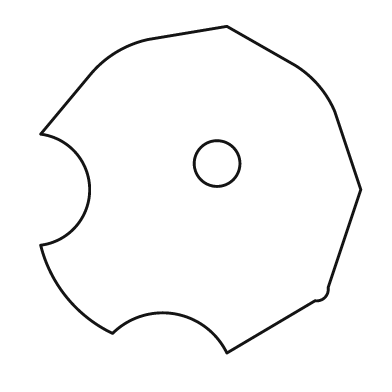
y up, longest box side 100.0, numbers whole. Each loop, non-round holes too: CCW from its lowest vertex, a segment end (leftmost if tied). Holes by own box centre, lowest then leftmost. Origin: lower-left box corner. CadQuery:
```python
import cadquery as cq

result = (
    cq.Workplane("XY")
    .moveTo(57.0, 0.0)
    .lineTo(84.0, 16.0)
    .threePointArc((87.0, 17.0), (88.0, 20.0))
    .lineTo(98.0, 50.0)
    .lineTo(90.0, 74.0)
    .threePointArc((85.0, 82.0), (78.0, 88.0))
    .lineTo(57.0, 100.0)
    .lineTo(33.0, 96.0)
    .threePointArc((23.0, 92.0), (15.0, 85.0))
    .lineTo(0.0, 67.0)
    .threePointArc((15.0, 50.0), (0.0, 33.0))
    .threePointArc((8.0, 17.0), (22.0, 6.0))
    .threePointArc((41.0, 12.0), (57.0, 0.0))
    .close()
    .moveTo(54.0, 58.0)
    .circle(7.0)
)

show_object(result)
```